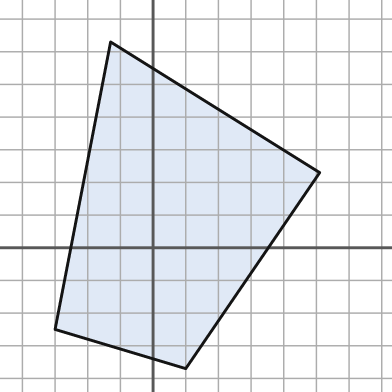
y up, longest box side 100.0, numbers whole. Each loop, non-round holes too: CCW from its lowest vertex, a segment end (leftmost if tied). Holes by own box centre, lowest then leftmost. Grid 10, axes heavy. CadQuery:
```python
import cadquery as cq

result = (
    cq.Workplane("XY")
    .moveTo(10.0, -37.0)
    .lineTo(51.0, 23.0)
    .lineTo(-13.0, 63.0)
    .lineTo(-30.0, -25.0)
    .close()
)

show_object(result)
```